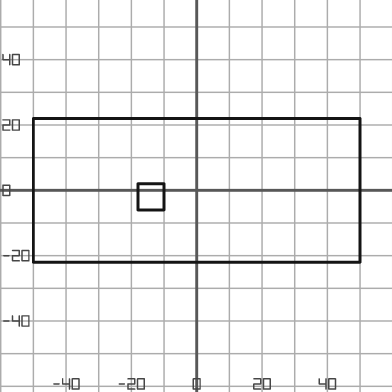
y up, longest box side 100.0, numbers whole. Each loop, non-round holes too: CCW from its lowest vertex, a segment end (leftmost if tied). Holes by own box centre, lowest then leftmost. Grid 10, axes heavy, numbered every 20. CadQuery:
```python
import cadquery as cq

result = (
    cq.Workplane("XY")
    .moveTo(-50.0, -22.0)
    .lineTo(50.0, -22.0)
    .lineTo(50.0, 22.0)
    .lineTo(-50.0, 22.0)
    .close()
    .moveTo(-18.0, -6.0)
    .lineTo(-10.0, -6.0)
    .lineTo(-10.0, 2.0)
    .lineTo(-18.0, 2.0)
    .close()
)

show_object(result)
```